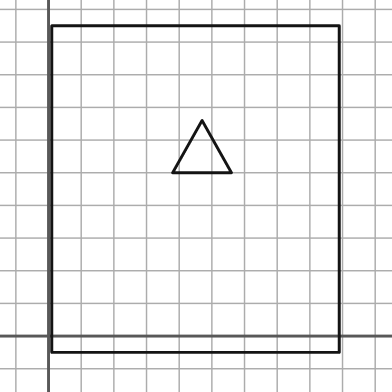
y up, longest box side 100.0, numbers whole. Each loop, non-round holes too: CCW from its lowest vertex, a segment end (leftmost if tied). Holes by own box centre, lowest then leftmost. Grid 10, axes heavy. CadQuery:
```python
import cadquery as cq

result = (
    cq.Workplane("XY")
    .moveTo(1.0, -5.0)
    .lineTo(89.0, -5.0)
    .lineTo(89.0, 95.0)
    .lineTo(1.0, 95.0)
    .close()
    .moveTo(38.0, 50.0)
    .lineTo(56.0, 50.0)
    .lineTo(47.0, 66.0)
    .close()
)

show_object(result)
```